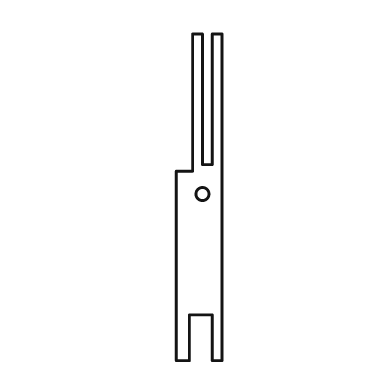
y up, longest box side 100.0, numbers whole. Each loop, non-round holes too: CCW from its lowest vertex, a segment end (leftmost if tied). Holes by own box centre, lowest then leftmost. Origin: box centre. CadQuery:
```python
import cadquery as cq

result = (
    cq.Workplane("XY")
    .moveTo(-7.0, -50.0)
    .lineTo(-3.0, -50.0)
    .lineTo(-3.0, -36.0)
    .lineTo(4.0, -36.0)
    .lineTo(4.0, -50.0)
    .lineTo(7.0, -50.0)
    .lineTo(7.0, 50.0)
    .lineTo(4.0, 50.0)
    .lineTo(4.0, 10.0)
    .lineTo(1.0, 10.0)
    .lineTo(1.0, 50.0)
    .lineTo(-2.0, 50.0)
    .lineTo(-2.0, 8.0)
    .lineTo(-7.0, 8.0)
    .close()
    .moveTo(1.0, 1.0)
    .circle(2.0)
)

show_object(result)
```